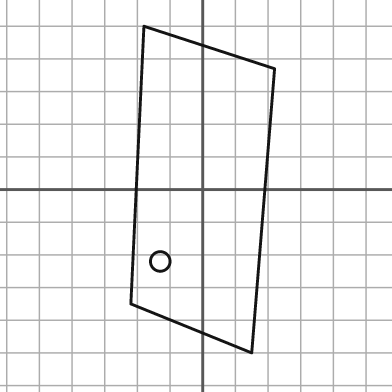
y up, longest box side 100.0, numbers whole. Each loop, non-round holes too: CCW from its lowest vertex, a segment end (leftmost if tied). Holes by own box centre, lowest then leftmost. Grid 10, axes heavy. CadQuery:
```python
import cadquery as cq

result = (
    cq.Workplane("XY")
    .moveTo(15.0, -50.0)
    .lineTo(22.0, 37.0)
    .lineTo(-18.0, 50.0)
    .lineTo(-22.0, -35.0)
    .close()
    .moveTo(-13.0, -22.0)
    .circle(3.0)
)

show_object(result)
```